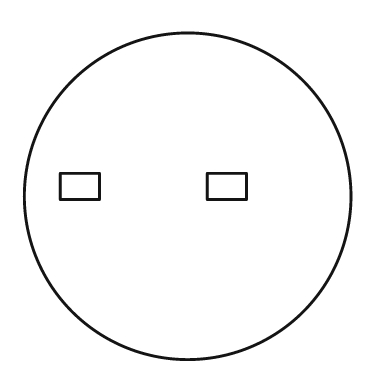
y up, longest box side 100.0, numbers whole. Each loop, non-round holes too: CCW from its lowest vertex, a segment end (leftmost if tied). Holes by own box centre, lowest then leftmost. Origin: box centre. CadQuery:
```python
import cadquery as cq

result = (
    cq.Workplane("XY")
    .moveTo(0.0, 0.0)
    .circle(50.0)
    .moveTo(-39.0, -1.0)
    .lineTo(-27.0, -1.0)
    .lineTo(-27.0, 7.0)
    .lineTo(-39.0, 7.0)
    .close()
    .moveTo(6.0, -1.0)
    .lineTo(18.0, -1.0)
    .lineTo(18.0, 7.0)
    .lineTo(6.0, 7.0)
    .close()
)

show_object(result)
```